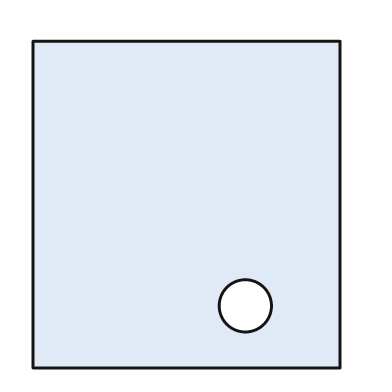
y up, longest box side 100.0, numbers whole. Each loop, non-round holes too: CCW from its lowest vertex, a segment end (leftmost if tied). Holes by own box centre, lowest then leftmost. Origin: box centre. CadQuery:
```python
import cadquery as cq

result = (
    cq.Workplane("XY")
    .moveTo(-47.0, -50.0)
    .lineTo(47.0, -50.0)
    .lineTo(47.0, 50.0)
    .lineTo(-47.0, 50.0)
    .close()
    .moveTo(18.0, -31.0)
    .circle(8.0)
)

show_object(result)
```